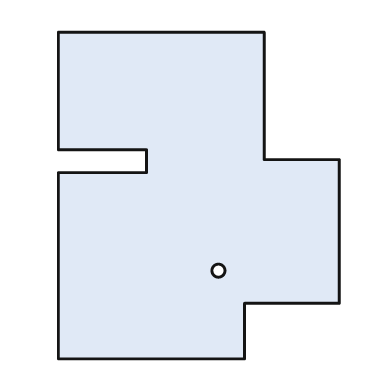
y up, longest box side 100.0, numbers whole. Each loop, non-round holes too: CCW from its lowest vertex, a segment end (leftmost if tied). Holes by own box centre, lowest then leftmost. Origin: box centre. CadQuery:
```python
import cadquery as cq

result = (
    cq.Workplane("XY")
    .moveTo(-43.0, -50.0)
    .lineTo(14.0, -50.0)
    .lineTo(14.0, -33.0)
    .lineTo(43.0, -33.0)
    .lineTo(43.0, 11.0)
    .lineTo(20.0, 11.0)
    .lineTo(20.0, 50.0)
    .lineTo(-43.0, 50.0)
    .lineTo(-43.0, 14.0)
    .lineTo(-16.0, 14.0)
    .lineTo(-16.0, 7.0)
    .lineTo(-43.0, 7.0)
    .close()
    .moveTo(6.0, -23.0)
    .circle(2.0)
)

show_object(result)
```